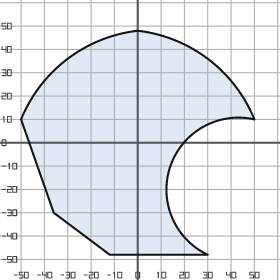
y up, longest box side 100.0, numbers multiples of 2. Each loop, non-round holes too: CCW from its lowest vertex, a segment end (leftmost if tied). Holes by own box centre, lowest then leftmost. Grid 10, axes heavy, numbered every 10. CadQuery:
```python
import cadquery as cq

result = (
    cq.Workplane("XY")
    .moveTo(-12.0, -48.0)
    .lineTo(30.0, -48.0)
    .threePointArc((14.0, -10.0), (50.0, 10.0))
    .threePointArc((30.0, 36.0), (0.0, 48.0))
    .threePointArc((-30.0, 36.0), (-50.0, 10.0))
    .lineTo(-36.0, -30.0)
    .close()
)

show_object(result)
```